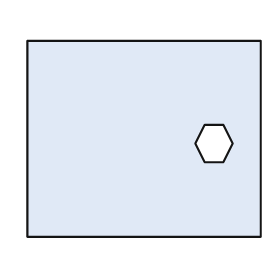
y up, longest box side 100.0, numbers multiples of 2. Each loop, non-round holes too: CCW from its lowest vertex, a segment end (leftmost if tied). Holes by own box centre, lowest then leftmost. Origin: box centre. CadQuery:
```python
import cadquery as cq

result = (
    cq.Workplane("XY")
    .moveTo(-50.0, -42.0)
    .lineTo(50.0, -42.0)
    .lineTo(50.0, 42.0)
    .lineTo(-50.0, 42.0)
    .close()
    .moveTo(26.0, -10.0)
    .lineTo(34.0, -10.0)
    .lineTo(38.0, -2.0)
    .lineTo(34.0, 6.0)
    .lineTo(26.0, 6.0)
    .lineTo(22.0, -2.0)
    .close()
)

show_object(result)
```